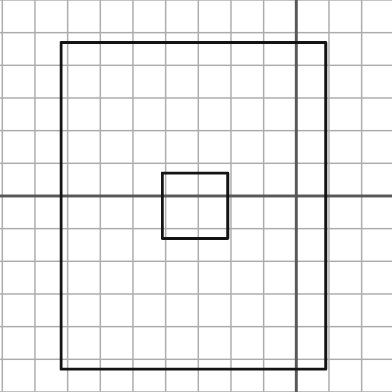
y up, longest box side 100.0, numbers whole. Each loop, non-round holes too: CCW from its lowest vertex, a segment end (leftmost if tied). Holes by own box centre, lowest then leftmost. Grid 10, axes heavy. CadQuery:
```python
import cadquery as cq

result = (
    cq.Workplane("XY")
    .moveTo(-72.0, -53.0)
    .lineTo(9.0, -53.0)
    .lineTo(9.0, 47.0)
    .lineTo(-72.0, 47.0)
    .close()
    .moveTo(-41.0, -13.0)
    .lineTo(-21.0, -13.0)
    .lineTo(-21.0, 7.0)
    .lineTo(-41.0, 7.0)
    .close()
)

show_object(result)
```